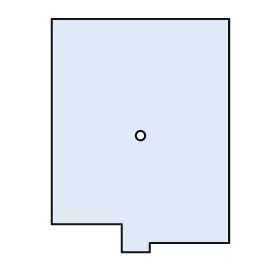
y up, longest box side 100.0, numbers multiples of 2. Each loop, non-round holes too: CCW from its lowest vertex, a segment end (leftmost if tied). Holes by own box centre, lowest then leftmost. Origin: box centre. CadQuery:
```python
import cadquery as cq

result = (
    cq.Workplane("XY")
    .moveTo(-8.0, -50.0)
    .lineTo(4.0, -50.0)
    .lineTo(4.0, -46.0)
    .lineTo(38.0, -46.0)
    .lineTo(38.0, 50.0)
    .lineTo(-38.0, 50.0)
    .lineTo(-38.0, -38.0)
    .lineTo(-8.0, -38.0)
    .close()
    .moveTo(0.0, 0.0)
    .circle(2.0)
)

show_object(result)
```